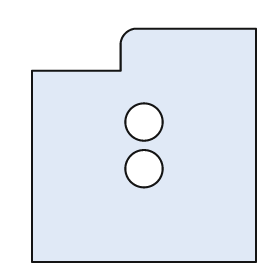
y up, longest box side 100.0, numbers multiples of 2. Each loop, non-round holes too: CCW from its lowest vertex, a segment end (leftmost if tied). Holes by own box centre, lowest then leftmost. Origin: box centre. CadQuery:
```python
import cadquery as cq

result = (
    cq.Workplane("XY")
    .moveTo(-48.0, -50.0)
    .lineTo(48.0, -50.0)
    .lineTo(48.0, 50.0)
    .lineTo(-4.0, 50.0)
    .threePointArc((-8.0, 48.0), (-10.0, 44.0))
    .lineTo(-10.0, 32.0)
    .lineTo(-48.0, 32.0)
    .close()
    .moveTo(0.0, -10.0)
    .circle(8.0)
    .moveTo(0.0, 10.0)
    .circle(8.0)
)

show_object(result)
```